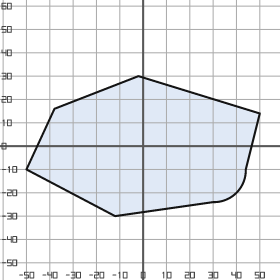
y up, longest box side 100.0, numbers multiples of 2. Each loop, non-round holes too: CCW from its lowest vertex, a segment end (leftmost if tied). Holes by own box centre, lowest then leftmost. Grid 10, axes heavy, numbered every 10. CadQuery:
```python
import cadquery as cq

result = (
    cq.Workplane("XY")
    .moveTo(-12.0, -30.0)
    .lineTo(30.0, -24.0)
    .threePointArc((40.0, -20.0), (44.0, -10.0))
    .lineTo(50.0, 14.0)
    .lineTo(-2.0, 30.0)
    .lineTo(-38.0, 16.0)
    .lineTo(-50.0, -10.0)
    .close()
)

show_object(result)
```